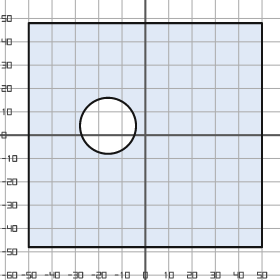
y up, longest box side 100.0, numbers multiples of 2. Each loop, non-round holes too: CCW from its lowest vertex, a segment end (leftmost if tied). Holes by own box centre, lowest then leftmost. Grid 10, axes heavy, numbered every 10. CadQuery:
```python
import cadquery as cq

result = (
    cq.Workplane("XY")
    .moveTo(-50.0, -48.0)
    .lineTo(50.0, -48.0)
    .lineTo(50.0, 48.0)
    .lineTo(-50.0, 48.0)
    .close()
    .moveTo(-16.0, 4.0)
    .circle(12.0)
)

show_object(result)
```